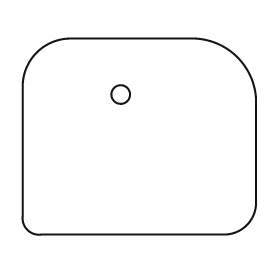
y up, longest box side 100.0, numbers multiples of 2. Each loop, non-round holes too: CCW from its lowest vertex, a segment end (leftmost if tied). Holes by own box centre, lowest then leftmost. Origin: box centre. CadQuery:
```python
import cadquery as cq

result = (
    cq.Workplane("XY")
    .moveTo(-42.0, -42.0)
    .lineTo(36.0, -42.0)
    .threePointArc((46.0, -38.0), (50.0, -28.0))
    .lineTo(50.0, 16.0)
    .threePointArc((42.0, 34.0), (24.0, 42.0))
    .lineTo(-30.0, 42.0)
    .threePointArc((-44.0, 36.0), (-50.0, 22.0))
    .lineTo(-50.0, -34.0)
    .threePointArc((-48.0, -40.0), (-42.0, -42.0))
    .close()
    .moveTo(-8.0, 18.0)
    .circle(4.0)
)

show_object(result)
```